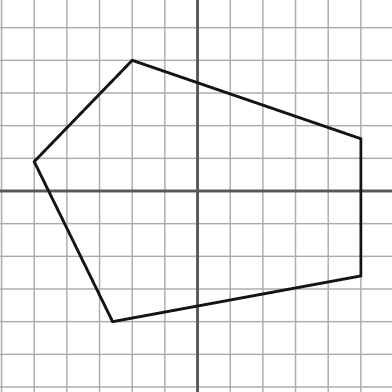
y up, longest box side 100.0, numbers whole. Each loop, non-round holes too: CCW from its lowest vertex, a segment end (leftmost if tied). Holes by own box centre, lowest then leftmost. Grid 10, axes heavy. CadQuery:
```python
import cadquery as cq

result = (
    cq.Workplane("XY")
    .moveTo(-26.0, -40.0)
    .lineTo(50.0, -26.0)
    .lineTo(50.0, 16.0)
    .lineTo(-20.0, 40.0)
    .lineTo(-50.0, 9.0)
    .close()
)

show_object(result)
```